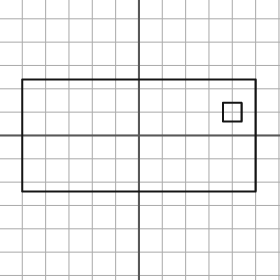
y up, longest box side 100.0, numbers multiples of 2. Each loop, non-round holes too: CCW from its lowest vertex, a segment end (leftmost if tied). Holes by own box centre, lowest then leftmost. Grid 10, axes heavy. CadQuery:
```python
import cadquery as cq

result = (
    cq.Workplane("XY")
    .moveTo(-50.0, -24.0)
    .lineTo(50.0, -24.0)
    .lineTo(50.0, 24.0)
    .lineTo(-50.0, 24.0)
    .close()
    .moveTo(36.0, 6.0)
    .lineTo(44.0, 6.0)
    .lineTo(44.0, 14.0)
    .lineTo(36.0, 14.0)
    .close()
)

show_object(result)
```